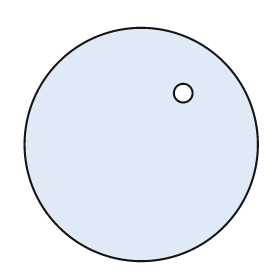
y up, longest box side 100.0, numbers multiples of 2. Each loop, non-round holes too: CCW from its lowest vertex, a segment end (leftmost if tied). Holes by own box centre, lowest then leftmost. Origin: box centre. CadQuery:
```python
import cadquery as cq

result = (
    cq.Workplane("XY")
    .moveTo(0.0, 0.0)
    .circle(50.0)
    .moveTo(18.0, 22.0)
    .circle(4.0)
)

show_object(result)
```